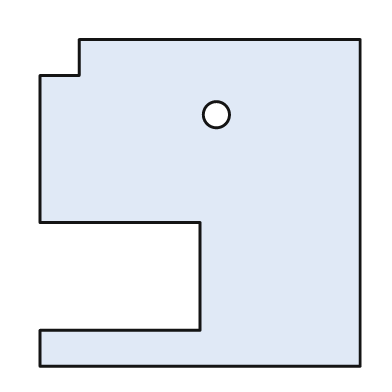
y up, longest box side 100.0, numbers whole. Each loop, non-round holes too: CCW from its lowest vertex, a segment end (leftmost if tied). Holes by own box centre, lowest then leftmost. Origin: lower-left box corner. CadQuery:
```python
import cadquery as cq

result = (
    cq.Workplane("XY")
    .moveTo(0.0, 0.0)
    .lineTo(98.0, 0.0)
    .lineTo(98.0, 100.0)
    .lineTo(12.0, 100.0)
    .lineTo(12.0, 89.0)
    .lineTo(0.0, 89.0)
    .lineTo(0.0, 44.0)
    .lineTo(49.0, 44.0)
    .lineTo(49.0, 11.0)
    .lineTo(0.0, 11.0)
    .close()
    .moveTo(54.0, 77.0)
    .circle(4.0)
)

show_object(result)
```